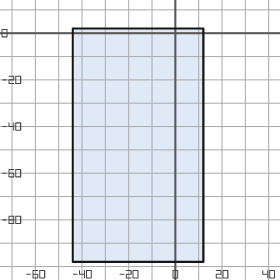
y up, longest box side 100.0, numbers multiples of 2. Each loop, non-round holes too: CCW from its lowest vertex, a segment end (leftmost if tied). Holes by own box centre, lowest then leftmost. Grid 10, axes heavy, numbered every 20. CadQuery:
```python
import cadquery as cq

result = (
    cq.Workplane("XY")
    .moveTo(-44.0, -98.0)
    .lineTo(12.0, -98.0)
    .lineTo(12.0, 2.0)
    .lineTo(-44.0, 2.0)
    .close()
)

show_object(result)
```